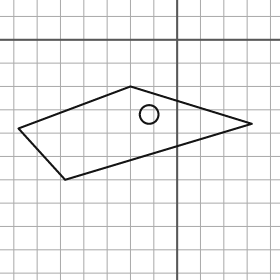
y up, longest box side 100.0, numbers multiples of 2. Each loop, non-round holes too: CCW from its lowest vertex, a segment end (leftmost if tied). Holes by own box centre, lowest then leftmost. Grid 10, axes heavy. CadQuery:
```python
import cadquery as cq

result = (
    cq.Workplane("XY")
    .moveTo(-48.0, -60.0)
    .lineTo(32.0, -36.0)
    .lineTo(-20.0, -20.0)
    .lineTo(-68.0, -38.0)
    .close()
    .moveTo(-12.0, -32.0)
    .circle(4.0)
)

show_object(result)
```